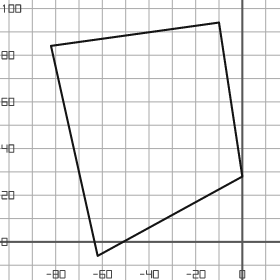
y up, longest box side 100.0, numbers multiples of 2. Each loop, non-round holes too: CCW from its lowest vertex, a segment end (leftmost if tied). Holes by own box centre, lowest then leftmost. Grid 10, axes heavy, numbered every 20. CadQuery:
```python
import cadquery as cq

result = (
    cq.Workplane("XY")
    .moveTo(-62.0, -6.0)
    .lineTo(0.0, 28.0)
    .lineTo(-10.0, 94.0)
    .lineTo(-82.0, 84.0)
    .close()
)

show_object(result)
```